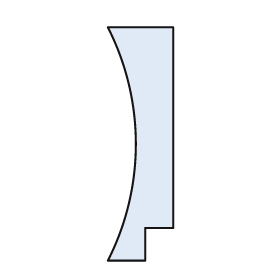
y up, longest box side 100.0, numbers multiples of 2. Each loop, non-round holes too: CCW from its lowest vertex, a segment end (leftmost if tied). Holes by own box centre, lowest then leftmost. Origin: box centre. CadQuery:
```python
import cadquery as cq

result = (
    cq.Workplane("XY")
    .moveTo(-14.0, -50.0)
    .lineTo(2.0, -50.0)
    .lineTo(2.0, -36.0)
    .lineTo(14.0, -36.0)
    .lineTo(14.0, 50.0)
    .lineTo(-14.0, 50.0)
    .threePointArc((-2.0, 0.0), (-14.0, -50.0))
    .close()
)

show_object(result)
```